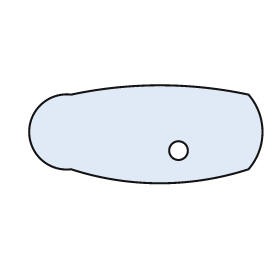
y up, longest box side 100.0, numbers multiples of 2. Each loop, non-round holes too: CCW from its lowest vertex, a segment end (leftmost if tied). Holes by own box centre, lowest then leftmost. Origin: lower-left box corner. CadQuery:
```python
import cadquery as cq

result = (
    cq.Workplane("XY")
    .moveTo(18.0, 6.0)
    .threePointArc((56.0, 0.0), (94.0, 6.0))
    .threePointArc((100.0, 22.0), (94.0, 38.0))
    .threePointArc((56.0, 42.0), (18.0, 38.0))
    .threePointArc((0.0, 22.0), (18.0, 6.0))
    .close()
    .moveTo(64.0, 14.0)
    .circle(4.0)
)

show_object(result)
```